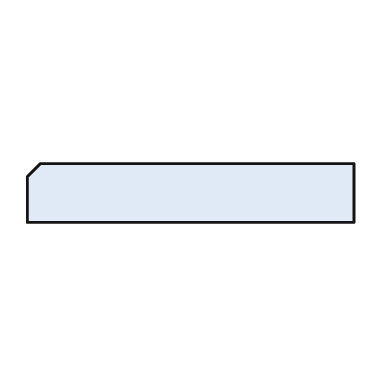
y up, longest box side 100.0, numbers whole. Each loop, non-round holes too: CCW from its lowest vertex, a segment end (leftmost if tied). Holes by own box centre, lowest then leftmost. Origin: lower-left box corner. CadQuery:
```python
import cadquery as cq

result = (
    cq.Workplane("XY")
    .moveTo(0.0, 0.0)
    .lineTo(100.0, 0.0)
    .lineTo(100.0, 18.0)
    .lineTo(4.0, 18.0)
    .lineTo(0.0, 14.0)
    .close()
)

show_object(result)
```